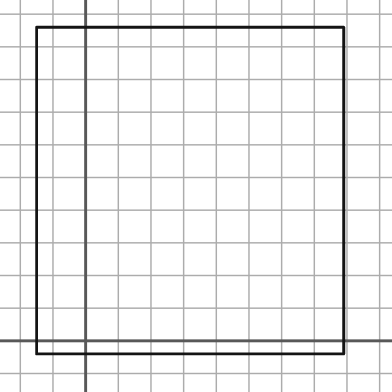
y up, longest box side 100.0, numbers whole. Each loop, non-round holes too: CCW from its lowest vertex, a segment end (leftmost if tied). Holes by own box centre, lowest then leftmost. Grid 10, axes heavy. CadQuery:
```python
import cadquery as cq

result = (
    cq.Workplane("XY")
    .moveTo(-15.0, -4.0)
    .lineTo(79.0, -4.0)
    .lineTo(79.0, 96.0)
    .lineTo(-15.0, 96.0)
    .close()
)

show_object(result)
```